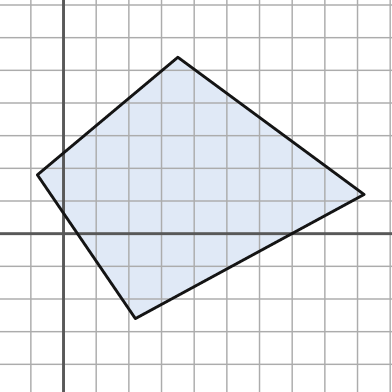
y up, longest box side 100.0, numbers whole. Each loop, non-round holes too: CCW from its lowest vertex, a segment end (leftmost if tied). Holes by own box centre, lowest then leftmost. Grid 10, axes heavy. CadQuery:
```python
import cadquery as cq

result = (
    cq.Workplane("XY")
    .moveTo(22.0, -26.0)
    .lineTo(92.0, 12.0)
    .lineTo(35.0, 54.0)
    .lineTo(-8.0, 18.0)
    .close()
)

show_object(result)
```